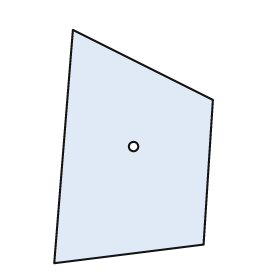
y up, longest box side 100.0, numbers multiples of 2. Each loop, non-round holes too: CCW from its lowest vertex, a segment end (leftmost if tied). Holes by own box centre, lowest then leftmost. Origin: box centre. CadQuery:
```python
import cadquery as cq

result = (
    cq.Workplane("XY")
    .moveTo(-34.0, -50.0)
    .lineTo(30.0, -42.0)
    .lineTo(34.0, 20.0)
    .lineTo(-26.0, 50.0)
    .close()
    .moveTo(0.0, 0.0)
    .circle(2.0)
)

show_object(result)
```